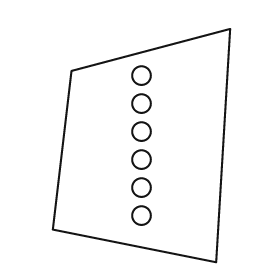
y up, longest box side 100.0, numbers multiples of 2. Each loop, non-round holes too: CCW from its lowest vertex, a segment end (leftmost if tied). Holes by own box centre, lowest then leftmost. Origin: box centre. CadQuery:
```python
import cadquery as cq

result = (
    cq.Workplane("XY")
    .moveTo(32.0, -50.0)
    .lineTo(38.0, 50.0)
    .lineTo(-30.0, 32.0)
    .lineTo(-38.0, -36.0)
    .close()
    .moveTo(0.0, -30.0)
    .circle(4.0)
    .moveTo(0.0, -18.0)
    .circle(4.0)
    .moveTo(0.0, -6.0)
    .circle(4.0)
    .moveTo(0.0, 6.0)
    .circle(4.0)
    .moveTo(0.0, 18.0)
    .circle(4.0)
    .moveTo(0.0, 30.0)
    .circle(4.0)
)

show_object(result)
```